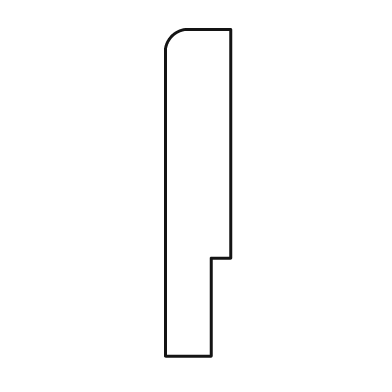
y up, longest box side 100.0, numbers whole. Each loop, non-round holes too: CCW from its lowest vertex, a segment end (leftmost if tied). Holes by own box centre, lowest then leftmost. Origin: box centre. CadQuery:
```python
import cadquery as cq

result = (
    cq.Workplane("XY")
    .moveTo(-10.0, -50.0)
    .lineTo(4.0, -50.0)
    .lineTo(4.0, -20.0)
    .lineTo(10.0, -20.0)
    .lineTo(10.0, 50.0)
    .lineTo(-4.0, 50.0)
    .threePointArc((-8.0, 48.0), (-10.0, 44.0))
    .close()
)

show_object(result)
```